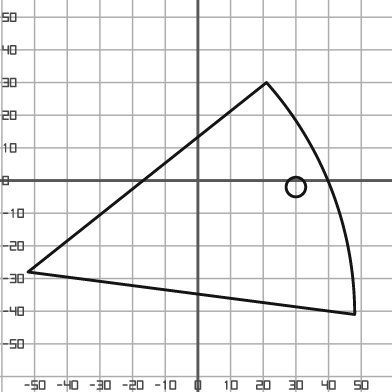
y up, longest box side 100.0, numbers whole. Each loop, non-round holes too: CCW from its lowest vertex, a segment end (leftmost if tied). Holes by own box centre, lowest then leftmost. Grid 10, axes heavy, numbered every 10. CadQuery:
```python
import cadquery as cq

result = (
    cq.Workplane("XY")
    .moveTo(48.0, -41.0)
    .threePointArc((41.0, -3.0), (21.0, 30.0))
    .lineTo(-52.0, -28.0)
    .close()
    .moveTo(30.0, -2.0)
    .circle(3.0)
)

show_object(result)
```